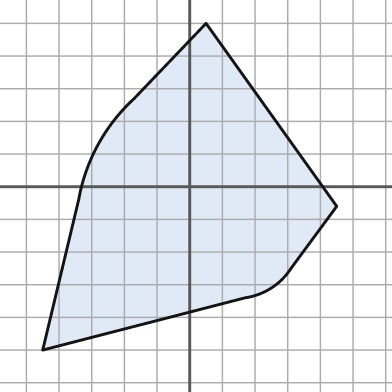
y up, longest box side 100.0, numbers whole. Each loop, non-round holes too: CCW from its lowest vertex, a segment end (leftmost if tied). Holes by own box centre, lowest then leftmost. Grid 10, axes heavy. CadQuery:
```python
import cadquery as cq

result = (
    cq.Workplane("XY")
    .moveTo(-45.0, -50.0)
    .lineTo(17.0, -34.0)
    .threePointArc((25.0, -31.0), (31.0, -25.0))
    .lineTo(45.0, -6.0)
    .lineTo(5.0, 50.0)
    .lineTo(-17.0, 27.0)
    .threePointArc((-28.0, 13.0), (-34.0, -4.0))
    .close()
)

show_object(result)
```